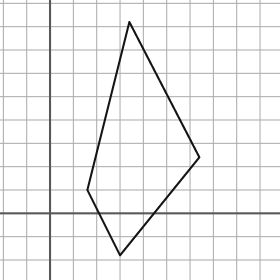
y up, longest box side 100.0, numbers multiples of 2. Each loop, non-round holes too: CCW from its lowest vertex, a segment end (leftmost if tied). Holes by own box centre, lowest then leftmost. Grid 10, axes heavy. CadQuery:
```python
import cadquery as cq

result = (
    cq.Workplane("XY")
    .moveTo(30.0, -18.0)
    .lineTo(64.0, 24.0)
    .lineTo(34.0, 82.0)
    .lineTo(16.0, 10.0)
    .close()
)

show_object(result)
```